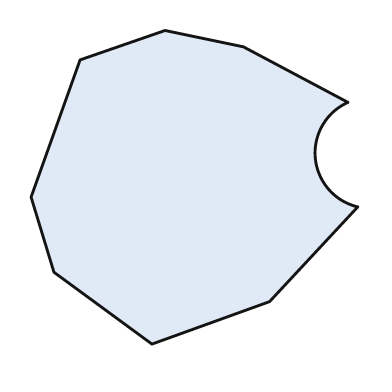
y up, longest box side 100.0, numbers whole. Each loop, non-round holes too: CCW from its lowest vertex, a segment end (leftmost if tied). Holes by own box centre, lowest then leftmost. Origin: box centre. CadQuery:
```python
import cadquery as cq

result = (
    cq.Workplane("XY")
    .moveTo(-13.0, -48.0)
    .lineTo(23.0, -35.0)
    .lineTo(50.0, -6.0)
    .threePointArc((37.0, 9.0), (47.0, 26.0))
    .lineTo(15.0, 43.0)
    .lineTo(-9.0, 48.0)
    .lineTo(-35.0, 39.0)
    .lineTo(-50.0, -3.0)
    .lineTo(-43.0, -26.0)
    .close()
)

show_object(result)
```